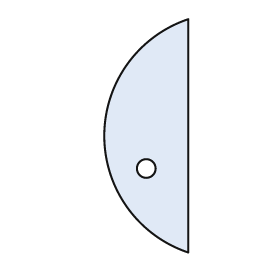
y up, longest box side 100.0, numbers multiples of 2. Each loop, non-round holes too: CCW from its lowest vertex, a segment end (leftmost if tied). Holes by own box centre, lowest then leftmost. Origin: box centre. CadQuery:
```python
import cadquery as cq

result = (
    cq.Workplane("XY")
    .moveTo(18.0, -50.0)
    .lineTo(18.0, 50.0)
    .threePointArc((-18.0, 0.0), (18.0, -50.0))
    .close()
    .moveTo(0.0, -14.0)
    .circle(4.0)
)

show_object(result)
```